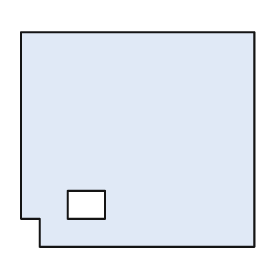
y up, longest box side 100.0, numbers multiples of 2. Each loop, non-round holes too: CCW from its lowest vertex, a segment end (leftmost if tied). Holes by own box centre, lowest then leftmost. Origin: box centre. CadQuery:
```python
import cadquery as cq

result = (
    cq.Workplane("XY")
    .moveTo(-42.0, -46.0)
    .lineTo(50.0, -46.0)
    .lineTo(50.0, 46.0)
    .lineTo(-50.0, 46.0)
    .lineTo(-50.0, -34.0)
    .lineTo(-42.0, -34.0)
    .close()
    .moveTo(-30.0, -34.0)
    .lineTo(-14.0, -34.0)
    .lineTo(-14.0, -22.0)
    .lineTo(-30.0, -22.0)
    .close()
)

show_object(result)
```